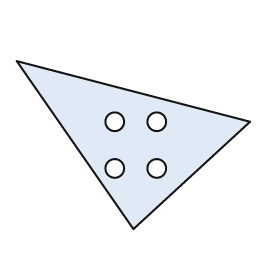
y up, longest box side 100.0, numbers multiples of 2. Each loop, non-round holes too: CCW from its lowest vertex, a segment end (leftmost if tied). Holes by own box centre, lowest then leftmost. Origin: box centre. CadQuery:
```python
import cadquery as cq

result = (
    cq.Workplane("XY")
    .moveTo(0.0, -36.0)
    .lineTo(50.0, 10.0)
    .lineTo(-50.0, 36.0)
    .close()
    .moveTo(-8.0, -10.0)
    .circle(4.0)
    .moveTo(10.0, -10.0)
    .circle(4.0)
    .moveTo(-8.0, 10.0)
    .circle(4.0)
    .moveTo(10.0, 10.0)
    .circle(4.0)
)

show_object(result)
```